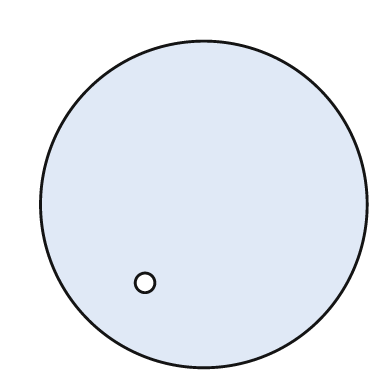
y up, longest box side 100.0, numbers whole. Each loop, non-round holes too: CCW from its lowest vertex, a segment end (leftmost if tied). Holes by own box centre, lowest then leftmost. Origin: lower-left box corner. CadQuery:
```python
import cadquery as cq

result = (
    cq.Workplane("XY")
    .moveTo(50.0, 50.0)
    .circle(50.0)
    .moveTo(32.0, 26.0)
    .circle(3.0)
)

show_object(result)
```